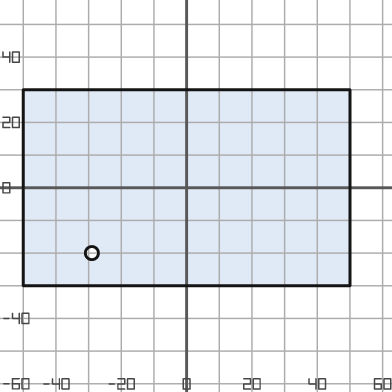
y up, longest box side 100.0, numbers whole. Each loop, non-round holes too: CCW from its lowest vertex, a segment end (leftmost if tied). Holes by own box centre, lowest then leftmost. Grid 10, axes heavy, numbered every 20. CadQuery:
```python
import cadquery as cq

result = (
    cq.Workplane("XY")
    .moveTo(-50.0, -30.0)
    .lineTo(50.0, -30.0)
    .lineTo(50.0, 30.0)
    .lineTo(-50.0, 30.0)
    .close()
    .moveTo(-29.0, -20.0)
    .circle(2.0)
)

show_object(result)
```